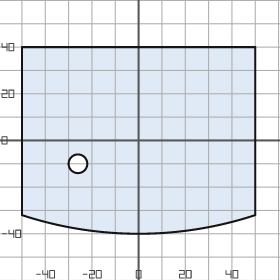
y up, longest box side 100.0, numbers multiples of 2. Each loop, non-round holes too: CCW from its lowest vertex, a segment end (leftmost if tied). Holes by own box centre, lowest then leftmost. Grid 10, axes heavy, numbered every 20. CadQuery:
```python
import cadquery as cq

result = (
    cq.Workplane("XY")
    .moveTo(-50.0, -32.0)
    .threePointArc((0.0, -40.0), (50.0, -32.0))
    .lineTo(50.0, 40.0)
    .lineTo(-50.0, 40.0)
    .close()
    .moveTo(-26.0, -10.0)
    .circle(4.0)
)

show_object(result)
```